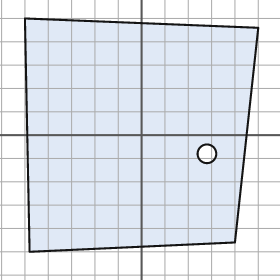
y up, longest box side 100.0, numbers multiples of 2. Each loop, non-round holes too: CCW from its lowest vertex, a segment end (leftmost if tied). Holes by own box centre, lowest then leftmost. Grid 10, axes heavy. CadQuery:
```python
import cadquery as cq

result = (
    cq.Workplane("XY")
    .moveTo(-48.0, -50.0)
    .lineTo(40.0, -46.0)
    .lineTo(50.0, 46.0)
    .lineTo(-50.0, 50.0)
    .close()
    .moveTo(28.0, -8.0)
    .circle(4.0)
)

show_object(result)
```